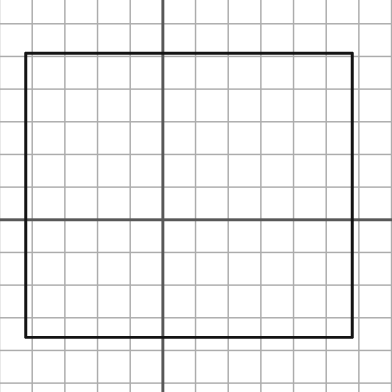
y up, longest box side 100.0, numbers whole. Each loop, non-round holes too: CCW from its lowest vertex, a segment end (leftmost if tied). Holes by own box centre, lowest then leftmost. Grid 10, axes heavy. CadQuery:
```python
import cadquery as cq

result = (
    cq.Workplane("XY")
    .moveTo(-42.0, -36.0)
    .lineTo(58.0, -36.0)
    .lineTo(58.0, 51.0)
    .lineTo(-42.0, 51.0)
    .close()
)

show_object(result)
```